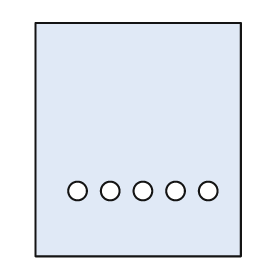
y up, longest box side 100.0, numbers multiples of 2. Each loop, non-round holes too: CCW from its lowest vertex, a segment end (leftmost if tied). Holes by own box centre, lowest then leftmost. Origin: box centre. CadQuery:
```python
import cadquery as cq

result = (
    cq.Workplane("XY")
    .moveTo(-44.0, -50.0)
    .lineTo(44.0, -50.0)
    .lineTo(44.0, 50.0)
    .lineTo(-44.0, 50.0)
    .close()
    .moveTo(-26.0, -22.0)
    .circle(4.0)
    .moveTo(-12.0, -22.0)
    .circle(4.0)
    .moveTo(2.0, -22.0)
    .circle(4.0)
    .moveTo(16.0, -22.0)
    .circle(4.0)
    .moveTo(30.0, -22.0)
    .circle(4.0)
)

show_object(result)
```